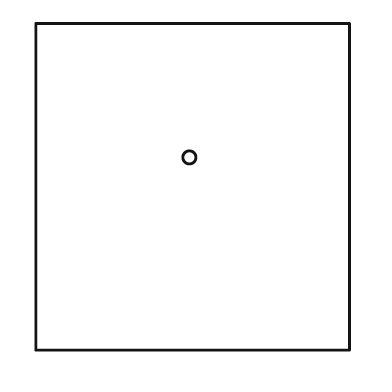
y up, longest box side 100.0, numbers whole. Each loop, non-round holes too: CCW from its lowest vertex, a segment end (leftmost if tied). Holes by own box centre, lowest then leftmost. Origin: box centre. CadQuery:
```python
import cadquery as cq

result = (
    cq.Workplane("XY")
    .moveTo(-48.0, -50.0)
    .lineTo(48.0, -50.0)
    .lineTo(48.0, 50.0)
    .lineTo(-48.0, 50.0)
    .close()
    .moveTo(-1.0, 9.0)
    .circle(2.0)
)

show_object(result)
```